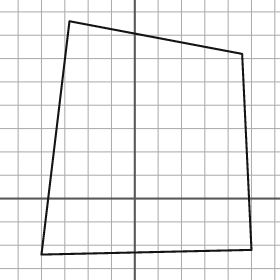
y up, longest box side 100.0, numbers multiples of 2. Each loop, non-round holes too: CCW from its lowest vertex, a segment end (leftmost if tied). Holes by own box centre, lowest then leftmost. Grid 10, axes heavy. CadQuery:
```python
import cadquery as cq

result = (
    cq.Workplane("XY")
    .moveTo(-40.0, -24.0)
    .lineTo(50.0, -22.0)
    .lineTo(46.0, 62.0)
    .lineTo(-28.0, 76.0)
    .close()
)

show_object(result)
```